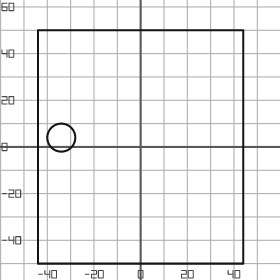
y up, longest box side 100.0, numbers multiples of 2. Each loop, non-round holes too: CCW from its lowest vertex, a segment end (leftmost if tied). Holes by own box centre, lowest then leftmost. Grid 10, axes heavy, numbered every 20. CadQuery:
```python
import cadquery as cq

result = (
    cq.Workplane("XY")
    .moveTo(-44.0, -50.0)
    .lineTo(44.0, -50.0)
    .lineTo(44.0, 50.0)
    .lineTo(-44.0, 50.0)
    .close()
    .moveTo(-34.0, 4.0)
    .circle(6.0)
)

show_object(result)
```